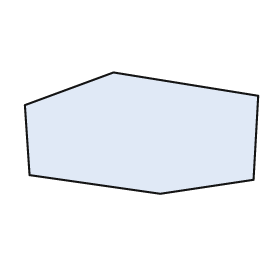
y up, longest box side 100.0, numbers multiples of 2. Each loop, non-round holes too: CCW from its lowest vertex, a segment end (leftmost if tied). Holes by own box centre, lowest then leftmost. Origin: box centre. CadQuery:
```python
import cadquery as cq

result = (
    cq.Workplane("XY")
    .moveTo(8.0, -26.0)
    .lineTo(48.0, -20.0)
    .lineTo(50.0, 16.0)
    .lineTo(-12.0, 26.0)
    .lineTo(-50.0, 12.0)
    .lineTo(-48.0, -18.0)
    .close()
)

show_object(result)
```